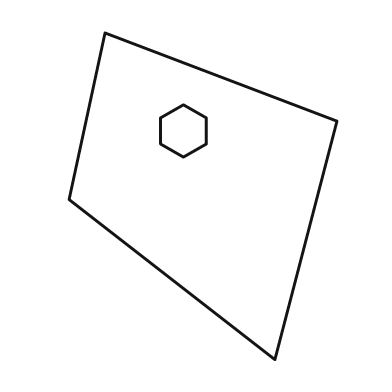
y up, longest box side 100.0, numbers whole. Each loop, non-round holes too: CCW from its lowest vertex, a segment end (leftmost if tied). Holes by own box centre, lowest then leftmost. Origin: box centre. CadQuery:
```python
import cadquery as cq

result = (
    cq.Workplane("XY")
    .moveTo(22.0, -50.0)
    .lineTo(41.0, 23.0)
    .lineTo(-30.0, 50.0)
    .lineTo(-41.0, -1.0)
    .close()
    .moveTo(-6.0, 12.0)
    .lineTo(1.0, 16.0)
    .lineTo(1.0, 24.0)
    .lineTo(-6.0, 28.0)
    .lineTo(-13.0, 24.0)
    .lineTo(-13.0, 16.0)
    .close()
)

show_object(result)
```